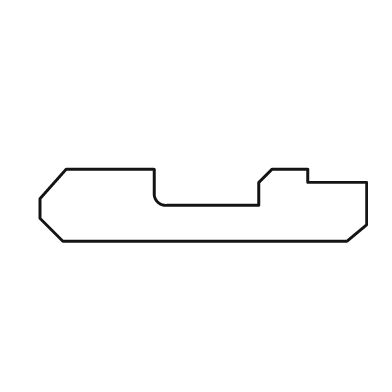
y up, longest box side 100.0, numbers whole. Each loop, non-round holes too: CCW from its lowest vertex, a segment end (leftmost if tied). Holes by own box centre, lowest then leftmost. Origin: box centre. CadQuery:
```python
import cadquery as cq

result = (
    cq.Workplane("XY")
    .moveTo(-43.0, -11.0)
    .lineTo(44.0, -11.0)
    .lineTo(50.0, -6.0)
    .lineTo(50.0, 7.0)
    .lineTo(32.0, 7.0)
    .lineTo(32.0, 11.0)
    .lineTo(21.0, 11.0)
    .lineTo(17.0, 7.0)
    .lineTo(17.0, 0.0)
    .lineTo(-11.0, 0.0)
    .threePointArc((-14.0, 1.0), (-15.0, 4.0))
    .lineTo(-15.0, 11.0)
    .lineTo(-42.0, 11.0)
    .lineTo(-50.0, 2.0)
    .lineTo(-50.0, -4.0)
    .close()
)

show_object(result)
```